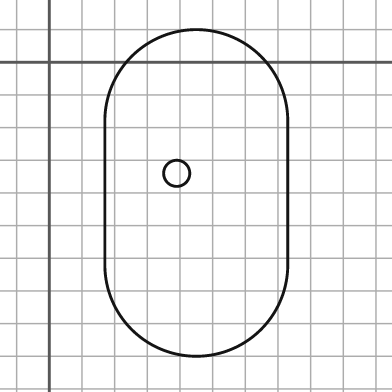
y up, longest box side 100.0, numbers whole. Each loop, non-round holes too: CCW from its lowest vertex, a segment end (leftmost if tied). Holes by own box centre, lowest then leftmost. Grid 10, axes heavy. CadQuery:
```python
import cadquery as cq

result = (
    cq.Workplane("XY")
    .moveTo(17.0, -62.0)
    .threePointArc((45.0, -90.0), (73.0, -62.0))
    .lineTo(73.0, -18.0)
    .threePointArc((45.0, 10.0), (17.0, -18.0))
    .close()
    .moveTo(39.0, -34.0)
    .circle(4.0)
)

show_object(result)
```